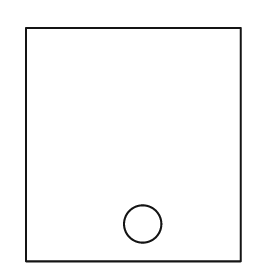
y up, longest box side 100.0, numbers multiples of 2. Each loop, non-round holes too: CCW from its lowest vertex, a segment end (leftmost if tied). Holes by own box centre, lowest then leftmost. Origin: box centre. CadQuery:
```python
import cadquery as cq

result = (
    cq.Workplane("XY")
    .moveTo(-46.0, -50.0)
    .lineTo(46.0, -50.0)
    .lineTo(46.0, 50.0)
    .lineTo(-46.0, 50.0)
    .close()
    .moveTo(4.0, -34.0)
    .circle(8.0)
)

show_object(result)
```